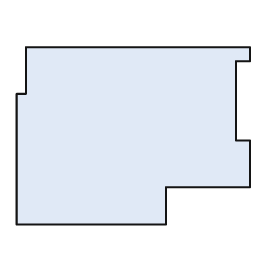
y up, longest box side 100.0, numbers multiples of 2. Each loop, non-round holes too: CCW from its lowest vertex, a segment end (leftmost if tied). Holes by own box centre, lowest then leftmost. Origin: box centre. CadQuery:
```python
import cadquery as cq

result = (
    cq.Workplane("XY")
    .moveTo(-50.0, -38.0)
    .lineTo(14.0, -38.0)
    .lineTo(14.0, -22.0)
    .lineTo(50.0, -22.0)
    .lineTo(50.0, -2.0)
    .lineTo(44.0, -2.0)
    .lineTo(44.0, 32.0)
    .lineTo(50.0, 32.0)
    .lineTo(50.0, 38.0)
    .lineTo(-46.0, 38.0)
    .lineTo(-46.0, 18.0)
    .lineTo(-50.0, 18.0)
    .close()
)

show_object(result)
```